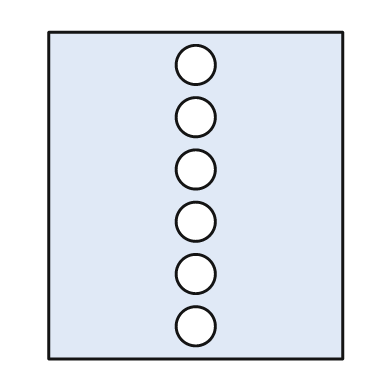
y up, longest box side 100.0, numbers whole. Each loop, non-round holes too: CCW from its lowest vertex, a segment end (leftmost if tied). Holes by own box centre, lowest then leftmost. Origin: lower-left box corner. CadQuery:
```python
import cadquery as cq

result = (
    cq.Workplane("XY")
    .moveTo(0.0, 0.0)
    .lineTo(90.0, 0.0)
    .lineTo(90.0, 100.0)
    .lineTo(0.0, 100.0)
    .close()
    .moveTo(45.0, 10.0)
    .circle(6.0)
    .moveTo(45.0, 26.0)
    .circle(6.0)
    .moveTo(45.0, 42.0)
    .circle(6.0)
    .moveTo(45.0, 58.0)
    .circle(6.0)
    .moveTo(45.0, 74.0)
    .circle(6.0)
    .moveTo(45.0, 90.0)
    .circle(6.0)
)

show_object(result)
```